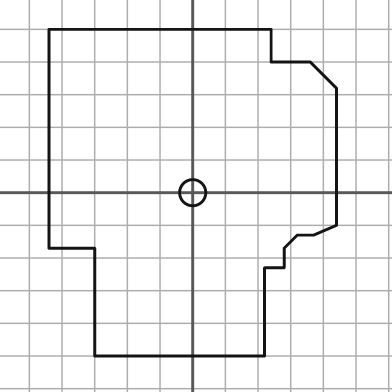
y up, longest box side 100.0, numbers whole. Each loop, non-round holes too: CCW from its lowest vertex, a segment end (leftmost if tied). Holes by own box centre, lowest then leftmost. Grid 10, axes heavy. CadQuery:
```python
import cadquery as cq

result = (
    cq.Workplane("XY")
    .moveTo(-30.0, -50.0)
    .lineTo(22.0, -50.0)
    .lineTo(22.0, -23.0)
    .lineTo(28.0, -23.0)
    .lineTo(28.0, -17.0)
    .lineTo(32.0, -13.0)
    .lineTo(37.0, -13.0)
    .lineTo(44.0, -10.0)
    .lineTo(44.0, 32.0)
    .lineTo(36.0, 40.0)
    .lineTo(24.0, 40.0)
    .lineTo(24.0, 50.0)
    .lineTo(-44.0, 50.0)
    .lineTo(-44.0, -17.0)
    .lineTo(-30.0, -17.0)
    .close()
    .moveTo(0.0, 0.0)
    .circle(4.0)
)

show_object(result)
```